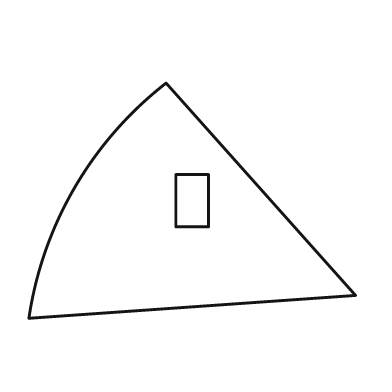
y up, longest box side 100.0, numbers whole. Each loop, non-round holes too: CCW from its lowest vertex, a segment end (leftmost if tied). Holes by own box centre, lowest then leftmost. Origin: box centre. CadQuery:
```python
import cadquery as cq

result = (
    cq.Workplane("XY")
    .moveTo(-50.0, -36.0)
    .lineTo(50.0, -29.0)
    .lineTo(-8.0, 36.0)
    .threePointArc((-36.0, 4.0), (-50.0, -36.0))
    .close()
    .moveTo(-5.0, -8.0)
    .lineTo(5.0, -8.0)
    .lineTo(5.0, 8.0)
    .lineTo(-5.0, 8.0)
    .close()
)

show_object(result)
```